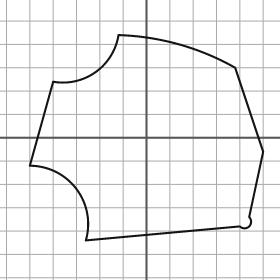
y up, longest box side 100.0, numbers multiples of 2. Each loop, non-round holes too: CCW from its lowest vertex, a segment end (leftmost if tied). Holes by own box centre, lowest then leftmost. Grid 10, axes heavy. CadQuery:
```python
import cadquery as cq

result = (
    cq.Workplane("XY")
    .moveTo(-26.0, -44.0)
    .lineTo(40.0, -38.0)
    .threePointArc((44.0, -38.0), (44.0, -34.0))
    .lineTo(50.0, -6.0)
    .lineTo(38.0, 30.0)
    .threePointArc((14.0, 40.0), (-12.0, 44.0))
    .threePointArc((-22.0, 28.0), (-40.0, 24.0))
    .lineTo(-50.0, -12.0)
    .threePointArc((-30.0, -22.0), (-26.0, -44.0))
    .close()
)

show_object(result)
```